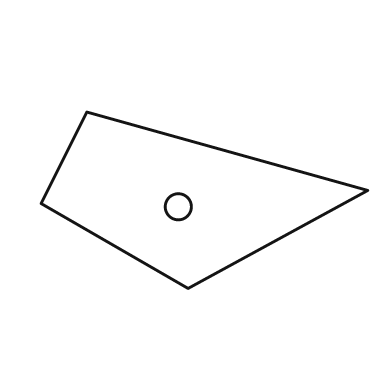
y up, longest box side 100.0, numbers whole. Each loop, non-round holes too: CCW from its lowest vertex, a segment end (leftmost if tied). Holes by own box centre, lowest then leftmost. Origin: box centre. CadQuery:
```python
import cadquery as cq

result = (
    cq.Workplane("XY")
    .moveTo(-5.0, -27.0)
    .lineTo(50.0, 3.0)
    .lineTo(-36.0, 27.0)
    .lineTo(-50.0, -1.0)
    .close()
    .moveTo(-8.0, -2.0)
    .circle(4.0)
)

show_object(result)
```